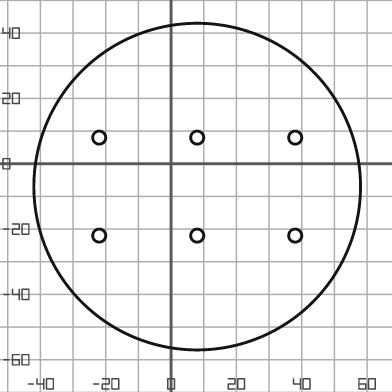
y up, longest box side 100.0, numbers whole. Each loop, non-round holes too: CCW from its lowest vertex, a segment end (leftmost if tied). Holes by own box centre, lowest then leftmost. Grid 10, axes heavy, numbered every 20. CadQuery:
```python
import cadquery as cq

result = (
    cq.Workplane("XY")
    .moveTo(8.0, -7.0)
    .circle(50.0)
    .moveTo(-22.0, -22.0)
    .circle(2.0)
    .moveTo(8.0, -22.0)
    .circle(2.0)
    .moveTo(38.0, -22.0)
    .circle(2.0)
    .moveTo(-22.0, 8.0)
    .circle(2.0)
    .moveTo(8.0, 8.0)
    .circle(2.0)
    .moveTo(38.0, 8.0)
    .circle(2.0)
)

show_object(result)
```